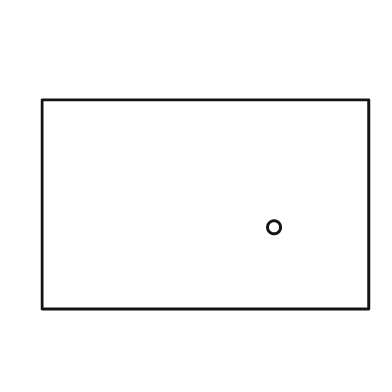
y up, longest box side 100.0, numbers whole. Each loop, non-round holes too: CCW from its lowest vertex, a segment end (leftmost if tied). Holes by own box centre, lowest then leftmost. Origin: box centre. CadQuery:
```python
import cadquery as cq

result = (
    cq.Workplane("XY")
    .moveTo(-50.0, -32.0)
    .lineTo(50.0, -32.0)
    .lineTo(50.0, 32.0)
    .lineTo(-50.0, 32.0)
    .close()
    .moveTo(21.0, -7.0)
    .circle(2.0)
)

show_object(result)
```